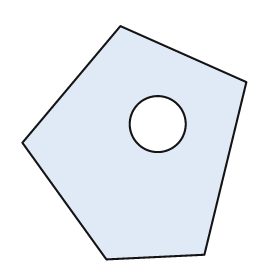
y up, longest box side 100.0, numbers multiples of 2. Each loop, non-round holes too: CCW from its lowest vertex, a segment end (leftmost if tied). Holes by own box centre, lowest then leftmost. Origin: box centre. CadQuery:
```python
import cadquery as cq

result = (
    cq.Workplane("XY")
    .moveTo(-12.0, -50.0)
    .lineTo(30.0, -48.0)
    .lineTo(48.0, 26.0)
    .lineTo(-6.0, 50.0)
    .lineTo(-48.0, 0.0)
    .close()
    .moveTo(10.0, 8.0)
    .circle(12.0)
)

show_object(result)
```